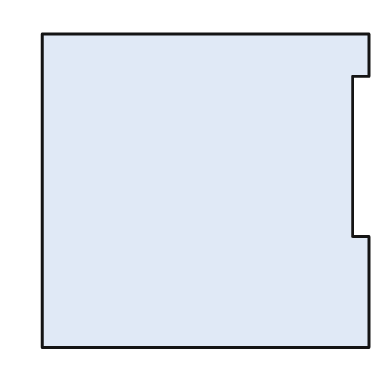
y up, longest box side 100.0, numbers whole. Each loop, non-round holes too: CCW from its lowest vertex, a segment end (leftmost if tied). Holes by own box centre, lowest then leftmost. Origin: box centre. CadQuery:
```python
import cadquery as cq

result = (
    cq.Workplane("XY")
    .moveTo(-50.0, -48.0)
    .lineTo(50.0, -48.0)
    .lineTo(50.0, -14.0)
    .lineTo(45.0, -14.0)
    .lineTo(45.0, 35.0)
    .lineTo(50.0, 35.0)
    .lineTo(50.0, 48.0)
    .lineTo(-50.0, 48.0)
    .close()
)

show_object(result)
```